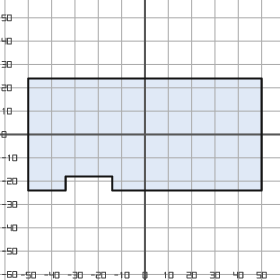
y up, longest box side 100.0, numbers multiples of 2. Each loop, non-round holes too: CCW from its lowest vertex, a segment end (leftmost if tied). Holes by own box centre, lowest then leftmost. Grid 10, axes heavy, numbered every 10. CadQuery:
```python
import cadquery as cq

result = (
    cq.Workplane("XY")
    .moveTo(-50.0, -24.0)
    .lineTo(-34.0, -24.0)
    .lineTo(-34.0, -18.0)
    .lineTo(-14.0, -18.0)
    .lineTo(-14.0, -24.0)
    .lineTo(50.0, -24.0)
    .lineTo(50.0, 24.0)
    .lineTo(-50.0, 24.0)
    .close()
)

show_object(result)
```